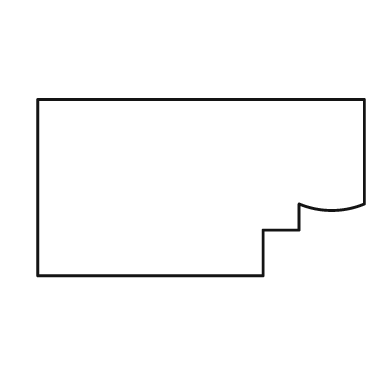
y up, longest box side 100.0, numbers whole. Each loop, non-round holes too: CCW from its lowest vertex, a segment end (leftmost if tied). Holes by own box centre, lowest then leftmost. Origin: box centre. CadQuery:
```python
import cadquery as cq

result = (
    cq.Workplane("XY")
    .moveTo(-50.0, -27.0)
    .lineTo(19.0, -27.0)
    .lineTo(19.0, -13.0)
    .lineTo(30.0, -13.0)
    .lineTo(30.0, -5.0)
    .threePointArc((40.0, -7.0), (50.0, -5.0))
    .lineTo(50.0, 27.0)
    .lineTo(-50.0, 27.0)
    .close()
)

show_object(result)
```